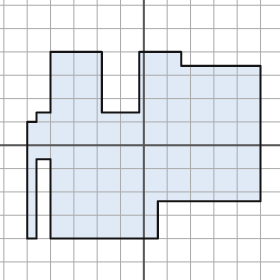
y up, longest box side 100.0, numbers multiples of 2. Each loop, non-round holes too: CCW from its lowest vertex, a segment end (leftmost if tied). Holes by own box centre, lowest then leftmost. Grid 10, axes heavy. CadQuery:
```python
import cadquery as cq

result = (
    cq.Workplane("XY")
    .moveTo(-50.0, -40.0)
    .lineTo(-46.0, -40.0)
    .lineTo(-46.0, -6.0)
    .lineTo(-40.0, -6.0)
    .lineTo(-40.0, -40.0)
    .lineTo(6.0, -40.0)
    .lineTo(6.0, -24.0)
    .lineTo(50.0, -24.0)
    .lineTo(50.0, 34.0)
    .lineTo(16.0, 34.0)
    .lineTo(16.0, 40.0)
    .lineTo(-2.0, 40.0)
    .lineTo(-2.0, 14.0)
    .lineTo(-18.0, 14.0)
    .lineTo(-18.0, 40.0)
    .lineTo(-40.0, 40.0)
    .lineTo(-40.0, 14.0)
    .lineTo(-46.0, 14.0)
    .lineTo(-46.0, 10.0)
    .lineTo(-50.0, 10.0)
    .close()
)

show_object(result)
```